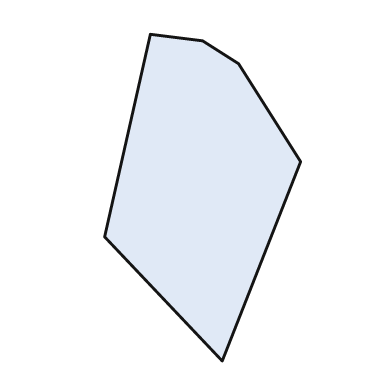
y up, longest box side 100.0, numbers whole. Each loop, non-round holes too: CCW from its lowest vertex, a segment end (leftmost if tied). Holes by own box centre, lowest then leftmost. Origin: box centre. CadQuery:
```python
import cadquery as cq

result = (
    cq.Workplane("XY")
    .moveTo(6.0, -50.0)
    .lineTo(30.0, 11.0)
    .lineTo(11.0, 41.0)
    .lineTo(0.0, 48.0)
    .lineTo(-16.0, 50.0)
    .lineTo(-30.0, -12.0)
    .close()
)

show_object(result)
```